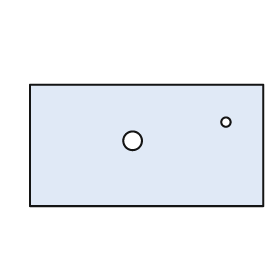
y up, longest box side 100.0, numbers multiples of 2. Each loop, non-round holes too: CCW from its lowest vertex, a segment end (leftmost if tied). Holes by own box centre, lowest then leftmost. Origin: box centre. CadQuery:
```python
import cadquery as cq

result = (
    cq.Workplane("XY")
    .moveTo(-50.0, -26.0)
    .lineTo(50.0, -26.0)
    .lineTo(50.0, 26.0)
    .lineTo(-50.0, 26.0)
    .close()
    .moveTo(-6.0, 2.0)
    .circle(4.0)
    .moveTo(34.0, 10.0)
    .circle(2.0)
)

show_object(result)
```